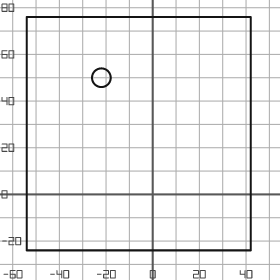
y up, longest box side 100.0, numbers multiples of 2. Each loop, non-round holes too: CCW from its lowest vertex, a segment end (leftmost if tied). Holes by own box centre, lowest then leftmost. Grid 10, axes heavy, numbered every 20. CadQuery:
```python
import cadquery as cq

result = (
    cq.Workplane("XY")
    .moveTo(-54.0, -24.0)
    .lineTo(42.0, -24.0)
    .lineTo(42.0, 76.0)
    .lineTo(-54.0, 76.0)
    .close()
    .moveTo(-22.0, 50.0)
    .circle(4.0)
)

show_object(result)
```